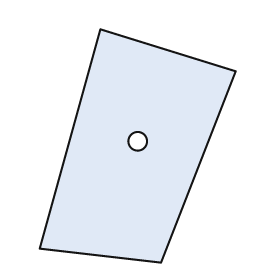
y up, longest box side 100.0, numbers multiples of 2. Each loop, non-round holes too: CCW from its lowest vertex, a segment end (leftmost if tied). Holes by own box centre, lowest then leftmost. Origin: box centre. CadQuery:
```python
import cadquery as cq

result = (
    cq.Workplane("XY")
    .moveTo(10.0, -50.0)
    .lineTo(42.0, 32.0)
    .lineTo(-16.0, 50.0)
    .lineTo(-42.0, -44.0)
    .close()
    .moveTo(0.0, 2.0)
    .circle(4.0)
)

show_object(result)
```